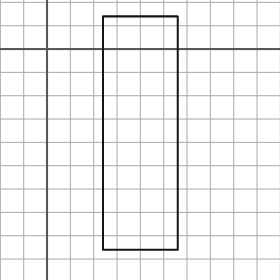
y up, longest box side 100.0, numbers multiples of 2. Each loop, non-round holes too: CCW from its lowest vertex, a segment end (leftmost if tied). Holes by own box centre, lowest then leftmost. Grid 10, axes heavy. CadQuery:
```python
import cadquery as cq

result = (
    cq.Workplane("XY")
    .moveTo(24.0, -86.0)
    .lineTo(56.0, -86.0)
    .lineTo(56.0, 14.0)
    .lineTo(24.0, 14.0)
    .close()
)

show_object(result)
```